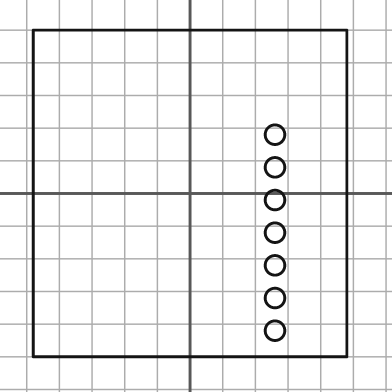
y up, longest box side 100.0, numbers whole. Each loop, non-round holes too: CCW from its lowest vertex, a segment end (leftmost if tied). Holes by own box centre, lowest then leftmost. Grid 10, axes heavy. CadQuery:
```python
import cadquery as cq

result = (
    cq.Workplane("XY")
    .moveTo(-48.0, -50.0)
    .lineTo(48.0, -50.0)
    .lineTo(48.0, 50.0)
    .lineTo(-48.0, 50.0)
    .close()
    .moveTo(26.0, -42.0)
    .circle(3.0)
    .moveTo(26.0, -32.0)
    .circle(3.0)
    .moveTo(26.0, -22.0)
    .circle(3.0)
    .moveTo(26.0, -12.0)
    .circle(3.0)
    .moveTo(26.0, -2.0)
    .circle(3.0)
    .moveTo(26.0, 8.0)
    .circle(3.0)
    .moveTo(26.0, 18.0)
    .circle(3.0)
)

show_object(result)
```